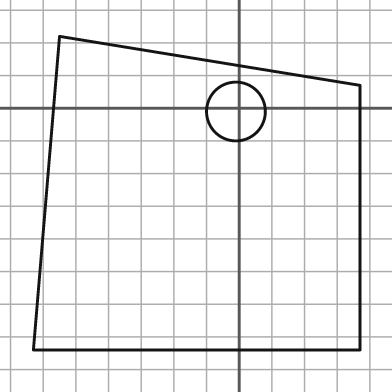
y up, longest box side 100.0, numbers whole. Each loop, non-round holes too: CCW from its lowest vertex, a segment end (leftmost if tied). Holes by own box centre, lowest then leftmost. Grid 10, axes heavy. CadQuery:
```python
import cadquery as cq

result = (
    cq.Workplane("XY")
    .moveTo(-63.0, -74.0)
    .lineTo(37.0, -74.0)
    .lineTo(37.0, 7.0)
    .lineTo(-55.0, 22.0)
    .close()
    .moveTo(-1.0, -1.0)
    .circle(9.0)
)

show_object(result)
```